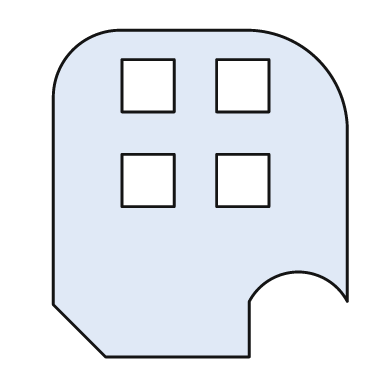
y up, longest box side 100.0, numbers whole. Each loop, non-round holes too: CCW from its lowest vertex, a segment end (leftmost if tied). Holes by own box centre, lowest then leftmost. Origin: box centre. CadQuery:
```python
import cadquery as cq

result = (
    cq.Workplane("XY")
    .moveTo(-29.0, -50.0)
    .lineTo(15.0, -50.0)
    .lineTo(15.0, -33.0)
    .threePointArc((30.0, -24.0), (45.0, -33.0))
    .lineTo(45.0, 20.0)
    .threePointArc((36.0, 41.0), (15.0, 50.0))
    .lineTo(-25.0, 50.0)
    .threePointArc((-39.0, 44.0), (-45.0, 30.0))
    .lineTo(-45.0, -34.0)
    .close()
    .moveTo(-24.0, -4.0)
    .lineTo(-8.0, -4.0)
    .lineTo(-8.0, 12.0)
    .lineTo(-24.0, 12.0)
    .close()
    .moveTo(5.0, -4.0)
    .lineTo(21.0, -4.0)
    .lineTo(21.0, 12.0)
    .lineTo(5.0, 12.0)
    .close()
    .moveTo(-24.0, 25.0)
    .lineTo(-8.0, 25.0)
    .lineTo(-8.0, 41.0)
    .lineTo(-24.0, 41.0)
    .close()
    .moveTo(5.0, 25.0)
    .lineTo(21.0, 25.0)
    .lineTo(21.0, 41.0)
    .lineTo(5.0, 41.0)
    .close()
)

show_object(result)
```